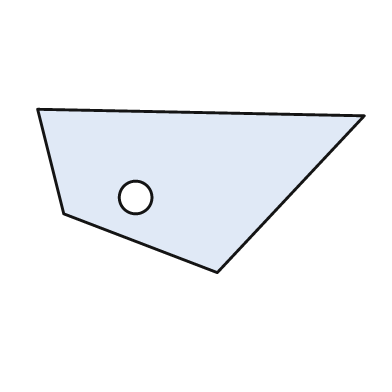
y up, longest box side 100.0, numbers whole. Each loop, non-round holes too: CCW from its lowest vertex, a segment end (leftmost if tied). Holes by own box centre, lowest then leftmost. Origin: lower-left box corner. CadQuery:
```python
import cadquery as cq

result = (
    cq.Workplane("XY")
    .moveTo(55.0, 0.0)
    .lineTo(100.0, 48.0)
    .lineTo(0.0, 50.0)
    .lineTo(8.0, 18.0)
    .close()
    .moveTo(30.0, 23.0)
    .circle(5.0)
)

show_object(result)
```